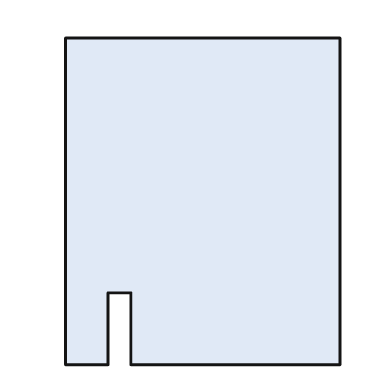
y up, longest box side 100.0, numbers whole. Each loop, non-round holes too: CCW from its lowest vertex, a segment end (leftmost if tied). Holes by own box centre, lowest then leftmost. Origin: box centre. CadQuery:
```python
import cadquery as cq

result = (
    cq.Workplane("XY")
    .moveTo(-42.0, -50.0)
    .lineTo(-29.0, -50.0)
    .lineTo(-29.0, -28.0)
    .lineTo(-22.0, -28.0)
    .lineTo(-22.0, -50.0)
    .lineTo(42.0, -50.0)
    .lineTo(42.0, 50.0)
    .lineTo(-42.0, 50.0)
    .close()
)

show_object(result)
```